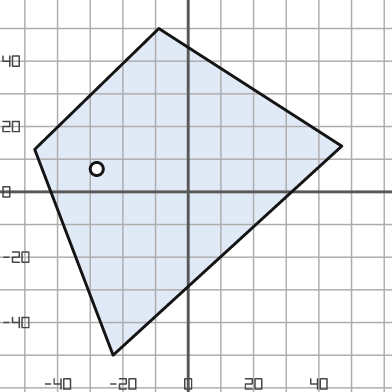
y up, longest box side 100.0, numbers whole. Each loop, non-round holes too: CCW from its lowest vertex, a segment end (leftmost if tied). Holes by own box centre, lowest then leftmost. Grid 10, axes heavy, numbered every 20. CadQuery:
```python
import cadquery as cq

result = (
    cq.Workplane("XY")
    .moveTo(-23.0, -50.0)
    .lineTo(47.0, 14.0)
    .lineTo(-9.0, 50.0)
    .lineTo(-47.0, 13.0)
    .close()
    .moveTo(-28.0, 7.0)
    .circle(2.0)
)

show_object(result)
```